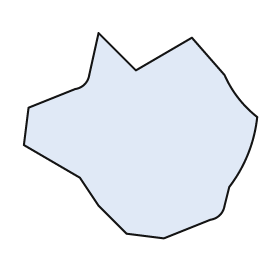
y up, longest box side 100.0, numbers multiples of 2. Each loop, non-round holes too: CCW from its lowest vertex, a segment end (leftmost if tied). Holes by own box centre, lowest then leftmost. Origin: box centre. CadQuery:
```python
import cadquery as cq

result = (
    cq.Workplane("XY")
    .moveTo(10.0, -44.0)
    .lineTo(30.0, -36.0)
    .threePointArc((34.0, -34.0), (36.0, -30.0))
    .lineTo(38.0, -22.0)
    .threePointArc((46.0, -8.0), (50.0, 8.0))
    .threePointArc((42.0, 16.0), (36.0, 26.0))
    .lineTo(22.0, 42.0)
    .lineTo(-2.0, 28.0)
    .lineTo(-18.0, 44.0)
    .lineTo(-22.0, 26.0)
    .threePointArc((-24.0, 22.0), (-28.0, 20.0))
    .lineTo(-48.0, 12.0)
    .lineTo(-50.0, -4.0)
    .lineTo(-26.0, -18.0)
    .lineTo(-18.0, -30.0)
    .lineTo(-6.0, -42.0)
    .close()
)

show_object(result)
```